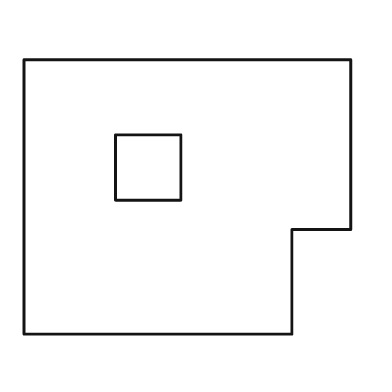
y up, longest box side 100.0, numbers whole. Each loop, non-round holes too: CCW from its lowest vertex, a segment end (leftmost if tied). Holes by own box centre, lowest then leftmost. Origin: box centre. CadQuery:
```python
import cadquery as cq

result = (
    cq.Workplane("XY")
    .moveTo(-50.0, -42.0)
    .lineTo(32.0, -42.0)
    .lineTo(32.0, -10.0)
    .lineTo(50.0, -10.0)
    .lineTo(50.0, 42.0)
    .lineTo(-50.0, 42.0)
    .close()
    .moveTo(-22.0, -1.0)
    .lineTo(-2.0, -1.0)
    .lineTo(-2.0, 19.0)
    .lineTo(-22.0, 19.0)
    .close()
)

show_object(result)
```